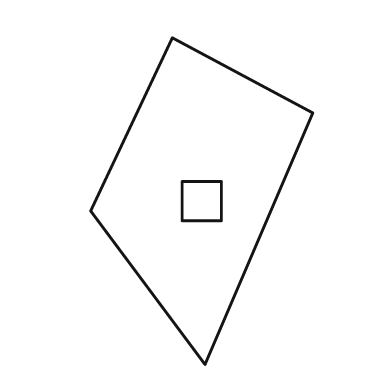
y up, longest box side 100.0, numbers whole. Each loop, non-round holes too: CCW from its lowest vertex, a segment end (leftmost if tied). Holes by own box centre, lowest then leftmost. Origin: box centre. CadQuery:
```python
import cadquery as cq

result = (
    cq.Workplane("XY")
    .moveTo(1.0, -50.0)
    .lineTo(34.0, 27.0)
    .lineTo(-9.0, 50.0)
    .lineTo(-34.0, -3.0)
    .close()
    .moveTo(-6.0, -6.0)
    .lineTo(6.0, -6.0)
    .lineTo(6.0, 6.0)
    .lineTo(-6.0, 6.0)
    .close()
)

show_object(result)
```